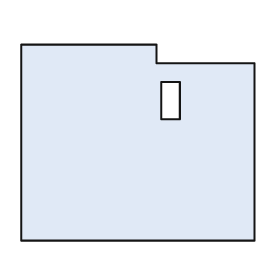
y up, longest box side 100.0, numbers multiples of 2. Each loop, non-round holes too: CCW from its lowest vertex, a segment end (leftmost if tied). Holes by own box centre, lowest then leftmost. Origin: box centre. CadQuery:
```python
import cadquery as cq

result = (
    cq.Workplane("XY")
    .moveTo(-50.0, -42.0)
    .lineTo(50.0, -42.0)
    .lineTo(50.0, 34.0)
    .lineTo(8.0, 34.0)
    .lineTo(8.0, 42.0)
    .lineTo(-50.0, 42.0)
    .close()
    .moveTo(10.0, 10.0)
    .lineTo(18.0, 10.0)
    .lineTo(18.0, 26.0)
    .lineTo(10.0, 26.0)
    .close()
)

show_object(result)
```